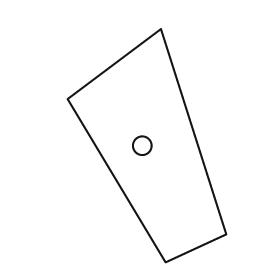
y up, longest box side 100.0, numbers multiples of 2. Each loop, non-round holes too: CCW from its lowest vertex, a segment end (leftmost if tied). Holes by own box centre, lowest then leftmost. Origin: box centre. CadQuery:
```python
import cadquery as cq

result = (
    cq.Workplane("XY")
    .moveTo(8.0, -50.0)
    .lineTo(34.0, -38.0)
    .lineTo(6.0, 50.0)
    .lineTo(-34.0, 20.0)
    .close()
    .moveTo(-2.0, 0.0)
    .circle(4.0)
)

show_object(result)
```